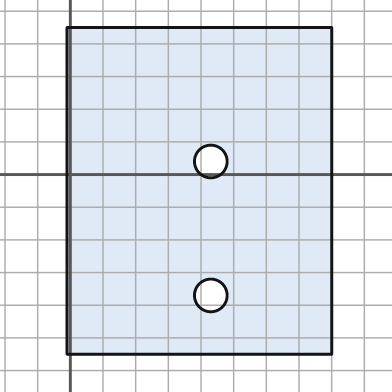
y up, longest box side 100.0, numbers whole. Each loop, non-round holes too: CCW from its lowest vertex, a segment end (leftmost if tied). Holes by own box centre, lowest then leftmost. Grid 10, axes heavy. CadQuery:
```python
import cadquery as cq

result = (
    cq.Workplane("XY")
    .moveTo(-1.0, -55.0)
    .lineTo(80.0, -55.0)
    .lineTo(80.0, 45.0)
    .lineTo(-1.0, 45.0)
    .close()
    .moveTo(43.0, -37.0)
    .circle(5.0)
    .moveTo(43.0, 4.0)
    .circle(5.0)
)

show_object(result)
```